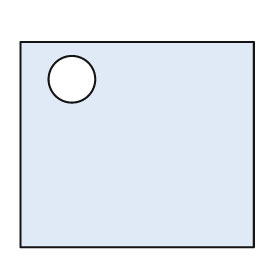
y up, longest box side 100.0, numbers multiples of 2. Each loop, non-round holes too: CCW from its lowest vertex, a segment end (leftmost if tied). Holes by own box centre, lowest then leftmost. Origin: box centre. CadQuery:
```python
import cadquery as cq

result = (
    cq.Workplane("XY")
    .moveTo(-50.0, -44.0)
    .lineTo(50.0, -44.0)
    .lineTo(50.0, 44.0)
    .lineTo(-50.0, 44.0)
    .close()
    .moveTo(-28.0, 28.0)
    .circle(10.0)
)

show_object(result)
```